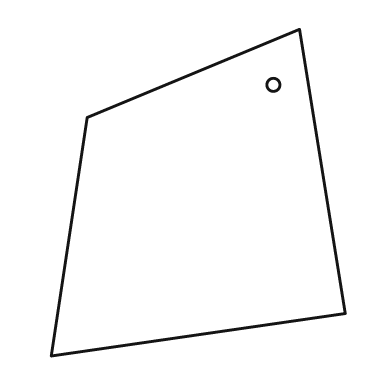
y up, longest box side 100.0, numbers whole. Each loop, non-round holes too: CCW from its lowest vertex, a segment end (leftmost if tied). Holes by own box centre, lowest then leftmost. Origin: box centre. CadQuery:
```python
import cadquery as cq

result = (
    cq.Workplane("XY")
    .moveTo(-45.0, -50.0)
    .lineTo(45.0, -37.0)
    .lineTo(31.0, 50.0)
    .lineTo(-34.0, 23.0)
    .close()
    .moveTo(23.0, 33.0)
    .circle(2.0)
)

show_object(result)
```